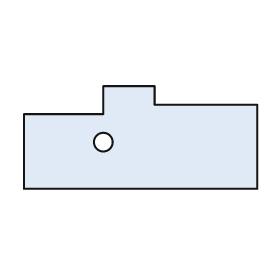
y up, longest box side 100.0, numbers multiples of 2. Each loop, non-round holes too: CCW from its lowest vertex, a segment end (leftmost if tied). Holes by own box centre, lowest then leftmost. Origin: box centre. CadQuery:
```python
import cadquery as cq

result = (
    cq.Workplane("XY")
    .moveTo(-50.0, -22.0)
    .lineTo(50.0, -22.0)
    .lineTo(50.0, 14.0)
    .lineTo(6.0, 14.0)
    .lineTo(6.0, 22.0)
    .lineTo(-16.0, 22.0)
    .lineTo(-16.0, 10.0)
    .lineTo(-50.0, 10.0)
    .close()
    .moveTo(-16.0, -2.0)
    .circle(4.0)
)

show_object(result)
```